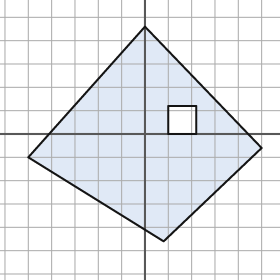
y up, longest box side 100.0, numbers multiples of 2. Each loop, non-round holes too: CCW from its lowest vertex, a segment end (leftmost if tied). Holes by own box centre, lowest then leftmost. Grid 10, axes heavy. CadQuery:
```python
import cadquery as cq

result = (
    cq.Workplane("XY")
    .moveTo(8.0, -46.0)
    .lineTo(50.0, -6.0)
    .lineTo(0.0, 46.0)
    .lineTo(-50.0, -10.0)
    .close()
    .moveTo(10.0, 0.0)
    .lineTo(22.0, 0.0)
    .lineTo(22.0, 12.0)
    .lineTo(10.0, 12.0)
    .close()
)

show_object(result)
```